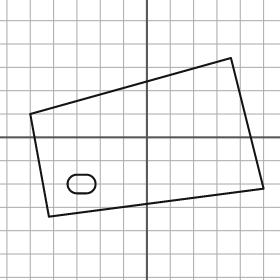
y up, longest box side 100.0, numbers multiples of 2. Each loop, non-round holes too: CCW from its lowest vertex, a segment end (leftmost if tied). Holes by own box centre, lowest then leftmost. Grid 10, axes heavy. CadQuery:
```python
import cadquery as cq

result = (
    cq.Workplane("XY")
    .moveTo(-42.0, -34.0)
    .lineTo(50.0, -22.0)
    .lineTo(36.0, 34.0)
    .lineTo(-50.0, 10.0)
    .close()
    .moveTo(-30.0, -24.0)
    .lineTo(-26.0, -24.0)
    .threePointArc((-22.0, -20.0), (-26.0, -16.0))
    .lineTo(-30.0, -16.0)
    .threePointArc((-34.0, -20.0), (-30.0, -24.0))
    .close()
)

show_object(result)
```